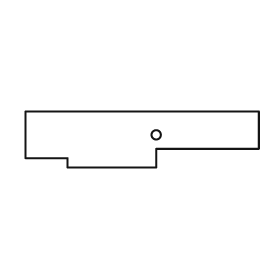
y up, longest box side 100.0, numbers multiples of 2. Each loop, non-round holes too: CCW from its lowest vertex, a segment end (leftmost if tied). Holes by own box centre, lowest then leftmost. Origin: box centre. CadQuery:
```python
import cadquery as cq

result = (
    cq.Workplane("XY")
    .moveTo(-32.0, -12.0)
    .lineTo(6.0, -12.0)
    .lineTo(6.0, -4.0)
    .lineTo(50.0, -4.0)
    .lineTo(50.0, 12.0)
    .lineTo(-50.0, 12.0)
    .lineTo(-50.0, -8.0)
    .lineTo(-32.0, -8.0)
    .close()
    .moveTo(6.0, 2.0)
    .circle(2.0)
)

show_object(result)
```